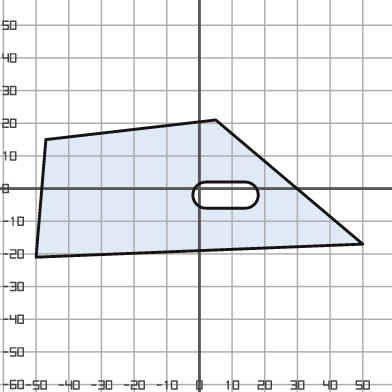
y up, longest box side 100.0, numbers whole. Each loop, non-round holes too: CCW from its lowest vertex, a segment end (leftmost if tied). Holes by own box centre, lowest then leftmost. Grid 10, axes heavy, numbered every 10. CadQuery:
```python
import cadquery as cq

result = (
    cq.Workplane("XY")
    .moveTo(-50.0, -21.0)
    .lineTo(50.0, -17.0)
    .lineTo(5.0, 21.0)
    .lineTo(-47.0, 15.0)
    .close()
    .moveTo(2.0, -6.0)
    .lineTo(14.0, -6.0)
    .threePointArc((18.0, -2.0), (14.0, 2.0))
    .lineTo(2.0, 2.0)
    .threePointArc((-2.0, -2.0), (2.0, -6.0))
    .close()
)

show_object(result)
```